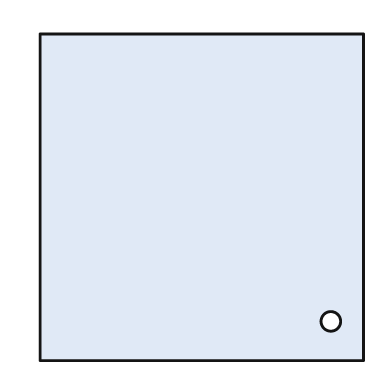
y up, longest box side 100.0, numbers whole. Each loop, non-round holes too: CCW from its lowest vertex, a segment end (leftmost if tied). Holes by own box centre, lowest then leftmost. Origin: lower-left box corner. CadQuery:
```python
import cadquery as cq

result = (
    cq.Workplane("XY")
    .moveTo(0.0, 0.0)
    .lineTo(99.0, 0.0)
    .lineTo(99.0, 100.0)
    .lineTo(0.0, 100.0)
    .close()
    .moveTo(89.0, 12.0)
    .circle(3.0)
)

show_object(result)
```